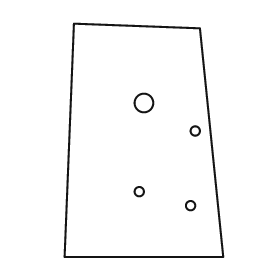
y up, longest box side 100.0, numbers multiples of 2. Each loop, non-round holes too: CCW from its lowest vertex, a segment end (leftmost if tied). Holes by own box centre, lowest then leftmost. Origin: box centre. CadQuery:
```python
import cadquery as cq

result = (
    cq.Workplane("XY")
    .moveTo(-34.0, -50.0)
    .lineTo(34.0, -50.0)
    .lineTo(24.0, 48.0)
    .lineTo(-30.0, 50.0)
    .close()
    .moveTo(20.0, -28.0)
    .circle(2.0)
    .moveTo(-2.0, -22.0)
    .circle(2.0)
    .moveTo(22.0, 4.0)
    .circle(2.0)
    .moveTo(0.0, 16.0)
    .circle(4.0)
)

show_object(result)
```